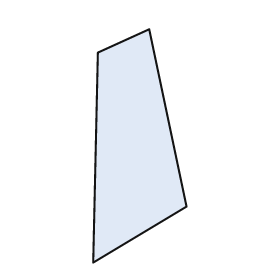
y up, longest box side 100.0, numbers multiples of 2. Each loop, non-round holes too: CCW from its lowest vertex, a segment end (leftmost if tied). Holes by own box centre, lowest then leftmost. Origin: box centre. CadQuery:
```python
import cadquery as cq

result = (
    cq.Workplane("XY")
    .moveTo(-20.0, -50.0)
    .lineTo(20.0, -26.0)
    .lineTo(4.0, 50.0)
    .lineTo(-18.0, 40.0)
    .close()
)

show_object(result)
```